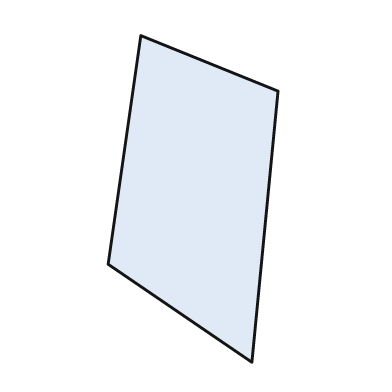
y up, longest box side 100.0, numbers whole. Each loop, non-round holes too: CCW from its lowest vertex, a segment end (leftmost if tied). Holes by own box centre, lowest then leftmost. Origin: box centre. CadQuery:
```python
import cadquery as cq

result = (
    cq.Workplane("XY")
    .moveTo(18.0, -50.0)
    .lineTo(26.0, 33.0)
    .lineTo(-16.0, 50.0)
    .lineTo(-26.0, -20.0)
    .close()
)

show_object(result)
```